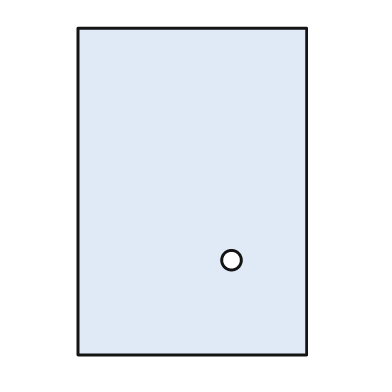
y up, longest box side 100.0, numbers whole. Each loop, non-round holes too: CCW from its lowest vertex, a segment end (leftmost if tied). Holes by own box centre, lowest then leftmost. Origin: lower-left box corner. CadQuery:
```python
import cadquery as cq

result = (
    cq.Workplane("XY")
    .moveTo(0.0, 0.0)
    .lineTo(70.0, 0.0)
    .lineTo(70.0, 100.0)
    .lineTo(0.0, 100.0)
    .close()
    .moveTo(47.0, 29.0)
    .circle(3.0)
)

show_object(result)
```